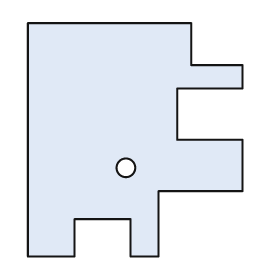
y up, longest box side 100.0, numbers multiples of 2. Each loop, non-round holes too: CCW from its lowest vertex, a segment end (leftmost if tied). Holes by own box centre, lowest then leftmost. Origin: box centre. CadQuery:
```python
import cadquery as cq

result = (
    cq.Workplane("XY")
    .moveTo(-46.0, -50.0)
    .lineTo(-26.0, -50.0)
    .lineTo(-26.0, -34.0)
    .lineTo(-2.0, -34.0)
    .lineTo(-2.0, -50.0)
    .lineTo(10.0, -50.0)
    .lineTo(10.0, -22.0)
    .lineTo(46.0, -22.0)
    .lineTo(46.0, 0.0)
    .lineTo(18.0, 0.0)
    .lineTo(18.0, 22.0)
    .lineTo(46.0, 22.0)
    .lineTo(46.0, 32.0)
    .lineTo(24.0, 32.0)
    .lineTo(24.0, 50.0)
    .lineTo(-46.0, 50.0)
    .close()
    .moveTo(-4.0, -12.0)
    .circle(4.0)
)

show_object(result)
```